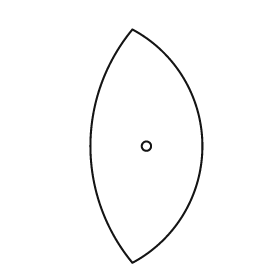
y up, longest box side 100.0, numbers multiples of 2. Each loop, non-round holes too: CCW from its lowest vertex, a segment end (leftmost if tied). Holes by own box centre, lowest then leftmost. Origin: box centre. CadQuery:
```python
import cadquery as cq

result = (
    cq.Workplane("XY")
    .moveTo(-6.0, -50.0)
    .threePointArc((24.0, 0.0), (-6.0, 50.0))
    .threePointArc((-24.0, 0.0), (-6.0, -50.0))
    .close()
    .moveTo(0.0, 0.0)
    .circle(2.0)
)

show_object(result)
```